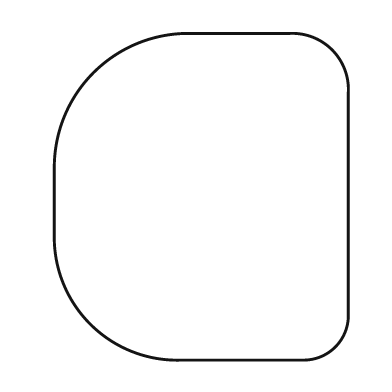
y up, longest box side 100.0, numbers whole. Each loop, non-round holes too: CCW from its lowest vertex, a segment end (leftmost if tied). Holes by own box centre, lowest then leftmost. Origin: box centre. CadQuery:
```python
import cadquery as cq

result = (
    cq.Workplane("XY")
    .moveTo(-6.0, -50.0)
    .lineTo(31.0, -50.0)
    .threePointArc((41.0, -46.0), (45.0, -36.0))
    .lineTo(45.0, 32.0)
    .threePointArc((40.0, 45.0), (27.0, 50.0))
    .lineTo(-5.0, 50.0)
    .threePointArc((-33.0, 38.0), (-45.0, 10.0))
    .lineTo(-45.0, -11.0)
    .threePointArc((-34.0, -39.0), (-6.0, -50.0))
    .close()
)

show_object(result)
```